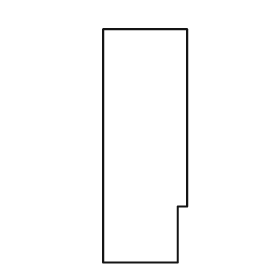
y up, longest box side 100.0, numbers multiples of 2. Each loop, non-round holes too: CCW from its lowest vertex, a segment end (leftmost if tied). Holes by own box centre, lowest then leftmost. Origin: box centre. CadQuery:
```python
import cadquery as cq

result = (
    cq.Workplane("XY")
    .moveTo(-18.0, -50.0)
    .lineTo(14.0, -50.0)
    .lineTo(14.0, -26.0)
    .lineTo(18.0, -26.0)
    .lineTo(18.0, 50.0)
    .lineTo(-18.0, 50.0)
    .close()
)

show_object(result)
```